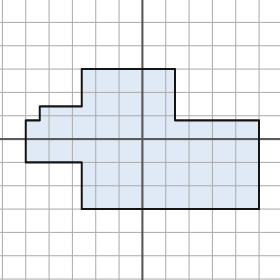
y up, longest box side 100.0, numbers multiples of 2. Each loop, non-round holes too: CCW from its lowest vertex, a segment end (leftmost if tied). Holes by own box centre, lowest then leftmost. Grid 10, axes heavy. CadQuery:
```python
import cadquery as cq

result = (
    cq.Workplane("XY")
    .moveTo(-26.0, -30.0)
    .lineTo(50.0, -30.0)
    .lineTo(50.0, 8.0)
    .lineTo(14.0, 8.0)
    .lineTo(14.0, 30.0)
    .lineTo(-26.0, 30.0)
    .lineTo(-26.0, 14.0)
    .lineTo(-44.0, 14.0)
    .lineTo(-44.0, 8.0)
    .lineTo(-50.0, 8.0)
    .lineTo(-50.0, -10.0)
    .lineTo(-26.0, -10.0)
    .close()
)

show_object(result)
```